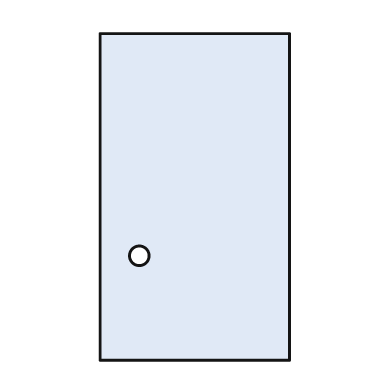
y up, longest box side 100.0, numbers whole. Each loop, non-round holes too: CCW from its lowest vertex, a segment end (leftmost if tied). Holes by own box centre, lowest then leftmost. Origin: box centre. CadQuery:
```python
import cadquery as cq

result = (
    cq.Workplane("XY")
    .moveTo(-29.0, -50.0)
    .lineTo(29.0, -50.0)
    .lineTo(29.0, 50.0)
    .lineTo(-29.0, 50.0)
    .close()
    .moveTo(-17.0, -18.0)
    .circle(3.0)
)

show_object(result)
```